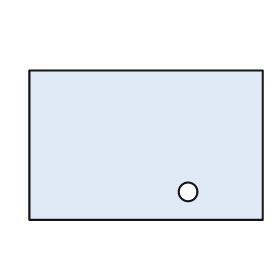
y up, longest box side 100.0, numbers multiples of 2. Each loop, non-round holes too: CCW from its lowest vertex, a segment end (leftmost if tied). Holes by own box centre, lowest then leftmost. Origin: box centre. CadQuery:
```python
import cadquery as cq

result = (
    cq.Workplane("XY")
    .moveTo(-50.0, -32.0)
    .lineTo(50.0, -32.0)
    .lineTo(50.0, 32.0)
    .lineTo(-50.0, 32.0)
    .close()
    .moveTo(18.0, -20.0)
    .circle(4.0)
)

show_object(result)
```